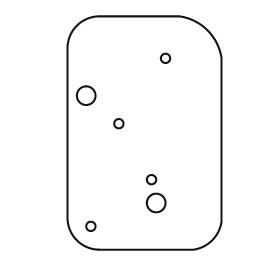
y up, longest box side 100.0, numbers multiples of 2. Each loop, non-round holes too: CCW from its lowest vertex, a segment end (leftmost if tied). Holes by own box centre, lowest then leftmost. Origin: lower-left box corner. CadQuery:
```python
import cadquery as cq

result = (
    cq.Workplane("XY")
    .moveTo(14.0, 0.0)
    .lineTo(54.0, 0.0)
    .threePointArc((62.0, 4.0), (66.0, 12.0))
    .lineTo(66.0, 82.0)
    .threePointArc((60.0, 94.0), (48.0, 100.0))
    .lineTo(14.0, 100.0)
    .threePointArc((4.0, 96.0), (0.0, 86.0))
    .lineTo(0.0, 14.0)
    .threePointArc((4.0, 4.0), (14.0, 0.0))
    .close()
    .moveTo(10.0, 10.0)
    .circle(2.0)
    .moveTo(38.0, 20.0)
    .circle(4.0)
    .moveTo(36.0, 30.0)
    .circle(2.0)
    .moveTo(22.0, 54.0)
    .circle(2.0)
    .moveTo(8.0, 66.0)
    .circle(4.0)
    .moveTo(42.0, 82.0)
    .circle(2.0)
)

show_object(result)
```